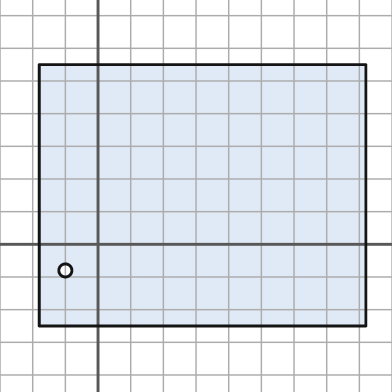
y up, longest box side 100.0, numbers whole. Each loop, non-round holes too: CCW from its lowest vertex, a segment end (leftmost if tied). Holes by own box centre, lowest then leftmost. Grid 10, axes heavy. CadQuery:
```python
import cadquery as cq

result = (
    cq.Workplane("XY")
    .moveTo(-18.0, -25.0)
    .lineTo(82.0, -25.0)
    .lineTo(82.0, 55.0)
    .lineTo(-18.0, 55.0)
    .close()
    .moveTo(-10.0, -8.0)
    .circle(2.0)
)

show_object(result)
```